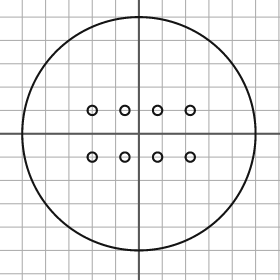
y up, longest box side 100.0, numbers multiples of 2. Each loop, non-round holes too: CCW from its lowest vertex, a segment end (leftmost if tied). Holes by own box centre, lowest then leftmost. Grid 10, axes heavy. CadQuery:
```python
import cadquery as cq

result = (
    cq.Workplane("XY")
    .moveTo(0.0, 0.0)
    .circle(50.0)
    .moveTo(-20.0, -10.0)
    .circle(2.0)
    .moveTo(-6.0, -10.0)
    .circle(2.0)
    .moveTo(8.0, -10.0)
    .circle(2.0)
    .moveTo(22.0, -10.0)
    .circle(2.0)
    .moveTo(-20.0, 10.0)
    .circle(2.0)
    .moveTo(-6.0, 10.0)
    .circle(2.0)
    .moveTo(8.0, 10.0)
    .circle(2.0)
    .moveTo(22.0, 10.0)
    .circle(2.0)
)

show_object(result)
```